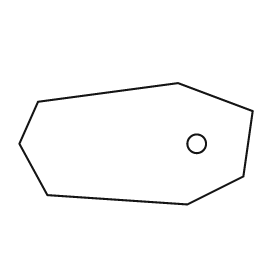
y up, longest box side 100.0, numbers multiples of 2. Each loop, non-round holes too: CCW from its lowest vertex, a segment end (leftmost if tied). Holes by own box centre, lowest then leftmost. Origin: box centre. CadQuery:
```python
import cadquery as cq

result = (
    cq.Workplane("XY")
    .moveTo(22.0, -26.0)
    .lineTo(46.0, -14.0)
    .lineTo(50.0, 14.0)
    .lineTo(18.0, 26.0)
    .lineTo(-42.0, 18.0)
    .lineTo(-50.0, 0.0)
    .lineTo(-38.0, -22.0)
    .close()
    .moveTo(26.0, 0.0)
    .circle(4.0)
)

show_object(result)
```